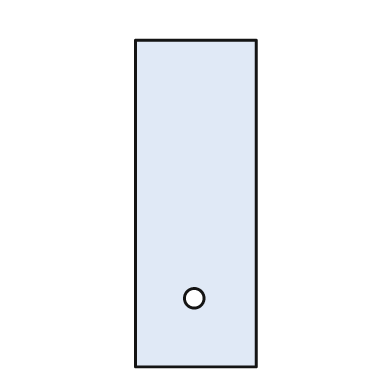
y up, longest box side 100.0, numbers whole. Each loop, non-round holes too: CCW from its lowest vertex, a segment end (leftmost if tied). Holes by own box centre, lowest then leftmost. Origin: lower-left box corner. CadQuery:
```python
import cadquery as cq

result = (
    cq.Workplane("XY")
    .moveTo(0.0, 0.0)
    .lineTo(37.0, 0.0)
    .lineTo(37.0, 100.0)
    .lineTo(0.0, 100.0)
    .close()
    .moveTo(18.0, 21.0)
    .circle(3.0)
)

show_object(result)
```